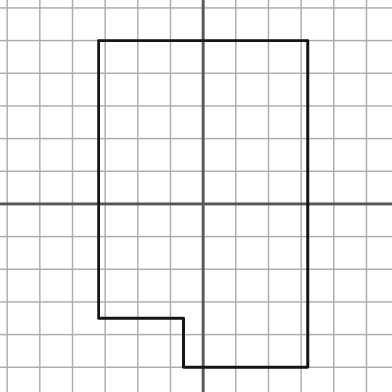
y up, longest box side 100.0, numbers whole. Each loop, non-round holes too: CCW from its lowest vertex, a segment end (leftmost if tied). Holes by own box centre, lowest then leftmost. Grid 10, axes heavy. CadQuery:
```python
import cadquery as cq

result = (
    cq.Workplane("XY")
    .moveTo(-6.0, -50.0)
    .lineTo(32.0, -50.0)
    .lineTo(32.0, 50.0)
    .lineTo(-32.0, 50.0)
    .lineTo(-32.0, -35.0)
    .lineTo(-6.0, -35.0)
    .close()
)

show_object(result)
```